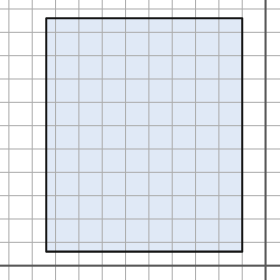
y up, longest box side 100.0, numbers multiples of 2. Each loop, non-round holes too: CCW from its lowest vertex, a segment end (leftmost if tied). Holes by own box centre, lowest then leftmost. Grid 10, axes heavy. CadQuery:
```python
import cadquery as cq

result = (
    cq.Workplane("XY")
    .moveTo(-94.0, 6.0)
    .lineTo(-10.0, 6.0)
    .lineTo(-10.0, 106.0)
    .lineTo(-94.0, 106.0)
    .close()
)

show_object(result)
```